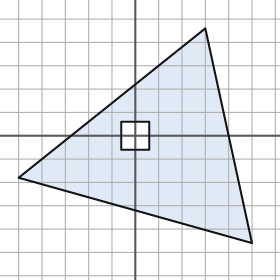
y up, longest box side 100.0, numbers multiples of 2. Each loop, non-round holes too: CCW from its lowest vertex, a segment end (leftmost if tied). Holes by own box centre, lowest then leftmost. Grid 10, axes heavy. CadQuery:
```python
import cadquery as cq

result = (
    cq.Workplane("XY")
    .moveTo(50.0, -46.0)
    .lineTo(30.0, 46.0)
    .lineTo(-50.0, -18.0)
    .close()
    .moveTo(-6.0, -6.0)
    .lineTo(6.0, -6.0)
    .lineTo(6.0, 6.0)
    .lineTo(-6.0, 6.0)
    .close()
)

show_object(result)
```